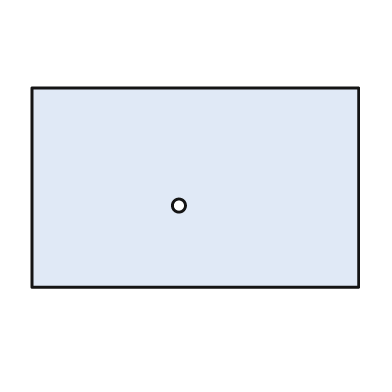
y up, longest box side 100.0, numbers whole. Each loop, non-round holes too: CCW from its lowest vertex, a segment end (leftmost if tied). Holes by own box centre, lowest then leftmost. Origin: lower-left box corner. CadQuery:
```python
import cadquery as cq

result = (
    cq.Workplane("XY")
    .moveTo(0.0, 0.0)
    .lineTo(100.0, 0.0)
    .lineTo(100.0, 61.0)
    .lineTo(0.0, 61.0)
    .close()
    .moveTo(45.0, 25.0)
    .circle(2.0)
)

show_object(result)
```